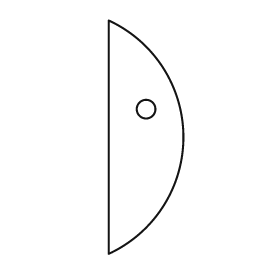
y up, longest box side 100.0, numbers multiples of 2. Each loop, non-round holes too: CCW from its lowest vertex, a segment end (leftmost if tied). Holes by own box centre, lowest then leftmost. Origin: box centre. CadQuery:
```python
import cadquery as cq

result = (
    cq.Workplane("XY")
    .moveTo(-16.0, -50.0)
    .threePointArc((16.0, 0.0), (-16.0, 50.0))
    .close()
    .moveTo(0.0, 12.0)
    .circle(4.0)
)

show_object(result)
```